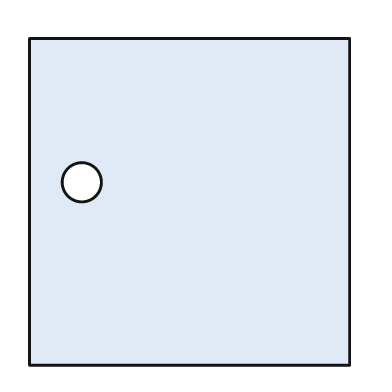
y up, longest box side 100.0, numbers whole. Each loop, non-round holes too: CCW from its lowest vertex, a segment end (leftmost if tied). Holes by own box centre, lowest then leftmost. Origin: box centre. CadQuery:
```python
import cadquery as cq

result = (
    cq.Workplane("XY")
    .moveTo(-49.0, -50.0)
    .lineTo(49.0, -50.0)
    .lineTo(49.0, 50.0)
    .lineTo(-49.0, 50.0)
    .close()
    .moveTo(-33.0, 6.0)
    .circle(6.0)
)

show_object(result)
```